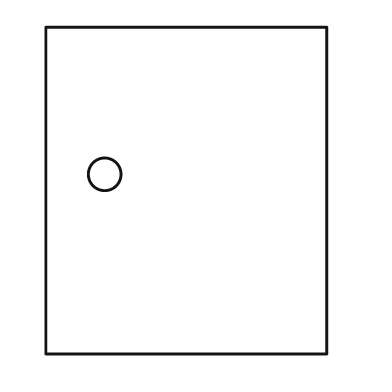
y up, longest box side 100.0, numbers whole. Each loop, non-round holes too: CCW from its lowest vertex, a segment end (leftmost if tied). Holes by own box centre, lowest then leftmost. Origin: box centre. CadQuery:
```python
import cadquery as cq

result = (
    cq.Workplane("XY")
    .moveTo(-43.0, -50.0)
    .lineTo(43.0, -50.0)
    .lineTo(43.0, 50.0)
    .lineTo(-43.0, 50.0)
    .close()
    .moveTo(-25.0, 5.0)
    .circle(5.0)
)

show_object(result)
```